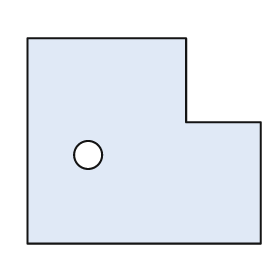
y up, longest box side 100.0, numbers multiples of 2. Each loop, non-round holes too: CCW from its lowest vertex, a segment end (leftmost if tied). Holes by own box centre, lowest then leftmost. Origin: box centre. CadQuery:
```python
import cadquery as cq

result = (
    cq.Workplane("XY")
    .moveTo(-50.0, -44.0)
    .lineTo(50.0, -44.0)
    .lineTo(50.0, 8.0)
    .lineTo(18.0, 8.0)
    .lineTo(18.0, 44.0)
    .lineTo(-50.0, 44.0)
    .close()
    .moveTo(-24.0, -6.0)
    .circle(6.0)
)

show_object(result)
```